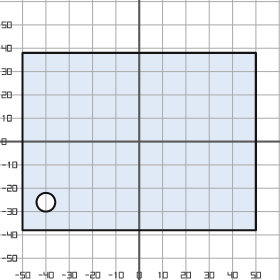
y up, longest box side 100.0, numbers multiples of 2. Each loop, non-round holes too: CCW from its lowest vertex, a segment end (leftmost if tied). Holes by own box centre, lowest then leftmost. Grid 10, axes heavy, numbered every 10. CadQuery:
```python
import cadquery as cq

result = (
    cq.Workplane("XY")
    .moveTo(-50.0, -38.0)
    .lineTo(50.0, -38.0)
    .lineTo(50.0, 38.0)
    .lineTo(-50.0, 38.0)
    .close()
    .moveTo(-40.0, -26.0)
    .circle(4.0)
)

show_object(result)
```